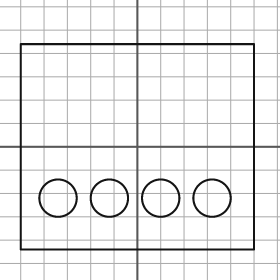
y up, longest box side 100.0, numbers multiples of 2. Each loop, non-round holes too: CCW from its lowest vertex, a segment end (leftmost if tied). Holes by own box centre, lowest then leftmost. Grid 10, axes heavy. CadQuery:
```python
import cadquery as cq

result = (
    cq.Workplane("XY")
    .moveTo(-50.0, -44.0)
    .lineTo(50.0, -44.0)
    .lineTo(50.0, 44.0)
    .lineTo(-50.0, 44.0)
    .close()
    .moveTo(-34.0, -22.0)
    .circle(8.0)
    .moveTo(-12.0, -22.0)
    .circle(8.0)
    .moveTo(10.0, -22.0)
    .circle(8.0)
    .moveTo(32.0, -22.0)
    .circle(8.0)
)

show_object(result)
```